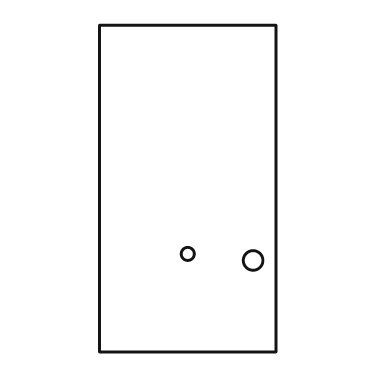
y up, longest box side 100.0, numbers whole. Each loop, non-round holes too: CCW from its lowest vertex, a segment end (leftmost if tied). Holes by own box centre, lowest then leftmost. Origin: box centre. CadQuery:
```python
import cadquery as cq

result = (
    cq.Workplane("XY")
    .moveTo(-27.0, -50.0)
    .lineTo(27.0, -50.0)
    .lineTo(27.0, 50.0)
    .lineTo(-27.0, 50.0)
    .close()
    .moveTo(20.0, -22.0)
    .circle(3.0)
    .moveTo(0.0, -20.0)
    .circle(2.0)
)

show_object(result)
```